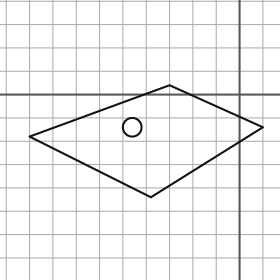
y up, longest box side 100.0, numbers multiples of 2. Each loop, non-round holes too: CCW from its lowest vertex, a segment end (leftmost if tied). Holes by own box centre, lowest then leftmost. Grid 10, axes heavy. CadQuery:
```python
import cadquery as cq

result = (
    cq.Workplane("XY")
    .moveTo(-38.0, -44.0)
    .lineTo(10.0, -14.0)
    .lineTo(-30.0, 4.0)
    .lineTo(-90.0, -18.0)
    .close()
    .moveTo(-46.0, -14.0)
    .circle(4.0)
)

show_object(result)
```